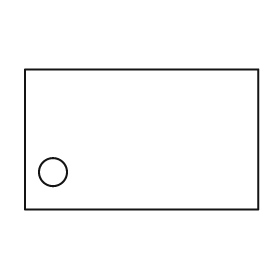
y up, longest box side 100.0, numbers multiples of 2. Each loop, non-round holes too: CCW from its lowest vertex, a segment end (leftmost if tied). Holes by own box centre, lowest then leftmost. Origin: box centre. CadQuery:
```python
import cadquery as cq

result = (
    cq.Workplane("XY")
    .moveTo(-50.0, -30.0)
    .lineTo(50.0, -30.0)
    .lineTo(50.0, 30.0)
    .lineTo(-50.0, 30.0)
    .close()
    .moveTo(-38.0, -14.0)
    .circle(6.0)
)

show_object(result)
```